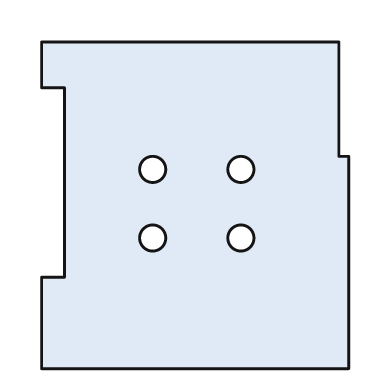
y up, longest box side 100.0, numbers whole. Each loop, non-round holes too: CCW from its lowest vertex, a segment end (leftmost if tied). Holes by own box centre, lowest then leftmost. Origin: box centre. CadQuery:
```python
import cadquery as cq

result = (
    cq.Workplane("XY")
    .moveTo(-47.0, -50.0)
    .lineTo(47.0, -50.0)
    .lineTo(47.0, 15.0)
    .lineTo(44.0, 15.0)
    .lineTo(44.0, 50.0)
    .lineTo(-47.0, 50.0)
    .lineTo(-47.0, 36.0)
    .lineTo(-40.0, 36.0)
    .lineTo(-40.0, -22.0)
    .lineTo(-47.0, -22.0)
    .close()
    .moveTo(-13.0, -10.0)
    .circle(4.0)
    .moveTo(14.0, -10.0)
    .circle(4.0)
    .moveTo(-13.0, 11.0)
    .circle(4.0)
    .moveTo(14.0, 11.0)
    .circle(4.0)
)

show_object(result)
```